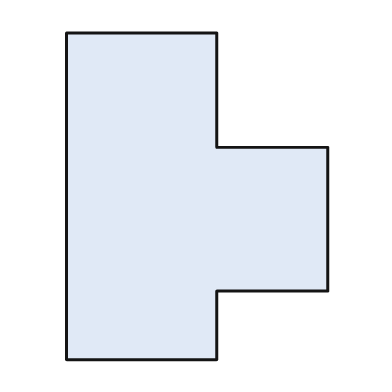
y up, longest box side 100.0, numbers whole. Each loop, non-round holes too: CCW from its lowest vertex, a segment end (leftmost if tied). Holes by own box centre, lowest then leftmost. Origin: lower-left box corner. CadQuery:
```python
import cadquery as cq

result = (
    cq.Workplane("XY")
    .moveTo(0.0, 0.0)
    .lineTo(46.0, 0.0)
    .lineTo(46.0, 21.0)
    .lineTo(80.0, 21.0)
    .lineTo(80.0, 65.0)
    .lineTo(46.0, 65.0)
    .lineTo(46.0, 100.0)
    .lineTo(0.0, 100.0)
    .close()
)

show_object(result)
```